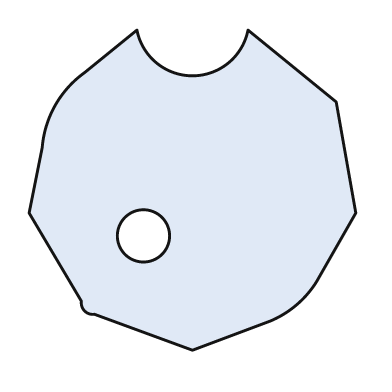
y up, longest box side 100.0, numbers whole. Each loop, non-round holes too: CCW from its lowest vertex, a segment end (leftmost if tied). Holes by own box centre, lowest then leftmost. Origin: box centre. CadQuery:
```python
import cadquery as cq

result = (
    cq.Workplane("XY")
    .moveTo(0.0, -49.0)
    .lineTo(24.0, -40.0)
    .threePointArc((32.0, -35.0), (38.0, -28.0))
    .lineTo(50.0, -7.0)
    .lineTo(44.0, 27.0)
    .lineTo(17.0, 49.0)
    .threePointArc((0.0, 35.0), (-17.0, 49.0))
    .lineTo(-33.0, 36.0)
    .threePointArc((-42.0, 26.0), (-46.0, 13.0))
    .lineTo(-50.0, -7.0)
    .lineTo(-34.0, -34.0)
    .threePointArc((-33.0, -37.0), (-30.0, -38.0))
    .close()
    .moveTo(-15.0, -14.0)
    .circle(8.0)
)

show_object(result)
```